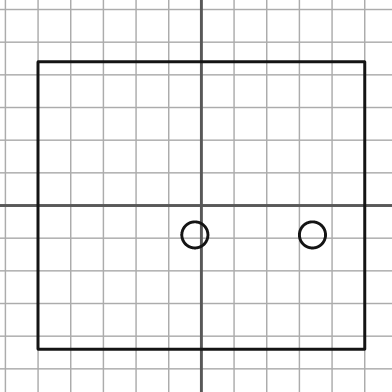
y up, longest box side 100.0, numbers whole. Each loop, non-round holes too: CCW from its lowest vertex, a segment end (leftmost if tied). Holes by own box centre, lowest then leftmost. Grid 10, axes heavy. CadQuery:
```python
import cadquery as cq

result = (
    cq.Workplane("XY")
    .moveTo(-50.0, -44.0)
    .lineTo(50.0, -44.0)
    .lineTo(50.0, 44.0)
    .lineTo(-50.0, 44.0)
    .close()
    .moveTo(-2.0, -9.0)
    .circle(4.0)
    .moveTo(34.0, -9.0)
    .circle(4.0)
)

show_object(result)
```